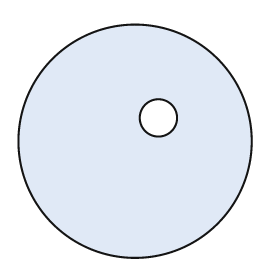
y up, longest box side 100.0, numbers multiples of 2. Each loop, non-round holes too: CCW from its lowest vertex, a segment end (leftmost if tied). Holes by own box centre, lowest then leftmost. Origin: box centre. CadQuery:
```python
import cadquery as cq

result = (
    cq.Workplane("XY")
    .moveTo(0.0, 0.0)
    .circle(50.0)
    .moveTo(10.0, 10.0)
    .circle(8.0)
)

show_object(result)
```